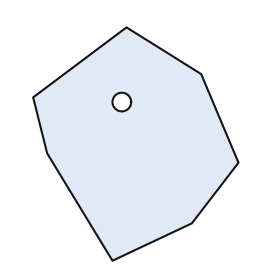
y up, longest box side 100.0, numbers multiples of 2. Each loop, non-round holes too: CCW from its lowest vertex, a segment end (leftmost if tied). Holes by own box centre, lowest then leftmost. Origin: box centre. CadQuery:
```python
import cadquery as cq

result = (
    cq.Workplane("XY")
    .moveTo(-10.0, -50.0)
    .lineTo(24.0, -34.0)
    .lineTo(44.0, -8.0)
    .lineTo(28.0, 30.0)
    .lineTo(-4.0, 50.0)
    .lineTo(-44.0, 20.0)
    .lineTo(-38.0, -4.0)
    .close()
    .moveTo(-6.0, 18.0)
    .circle(4.0)
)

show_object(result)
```